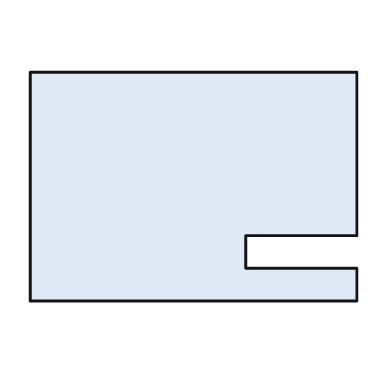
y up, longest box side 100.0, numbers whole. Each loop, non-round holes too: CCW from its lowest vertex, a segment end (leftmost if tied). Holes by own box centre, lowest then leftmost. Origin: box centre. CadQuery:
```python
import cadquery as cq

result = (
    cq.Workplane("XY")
    .moveTo(-50.0, -35.0)
    .lineTo(50.0, -35.0)
    .lineTo(50.0, -25.0)
    .lineTo(16.0, -25.0)
    .lineTo(16.0, -15.0)
    .lineTo(50.0, -15.0)
    .lineTo(50.0, 35.0)
    .lineTo(-50.0, 35.0)
    .close()
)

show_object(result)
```